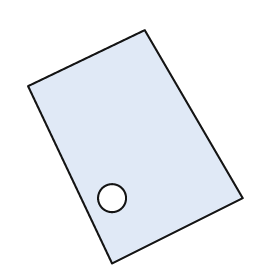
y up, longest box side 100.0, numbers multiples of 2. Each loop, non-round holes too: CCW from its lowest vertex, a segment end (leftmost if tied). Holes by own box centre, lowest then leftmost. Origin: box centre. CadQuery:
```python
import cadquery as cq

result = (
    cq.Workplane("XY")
    .moveTo(-10.0, -50.0)
    .lineTo(46.0, -22.0)
    .lineTo(4.0, 50.0)
    .lineTo(-46.0, 26.0)
    .close()
    .moveTo(-10.0, -22.0)
    .circle(6.0)
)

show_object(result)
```